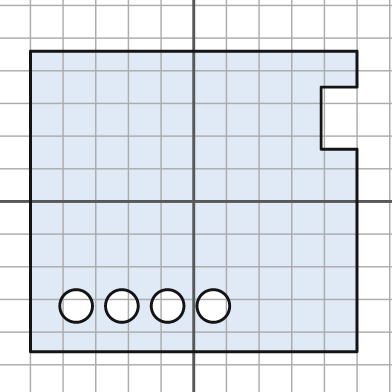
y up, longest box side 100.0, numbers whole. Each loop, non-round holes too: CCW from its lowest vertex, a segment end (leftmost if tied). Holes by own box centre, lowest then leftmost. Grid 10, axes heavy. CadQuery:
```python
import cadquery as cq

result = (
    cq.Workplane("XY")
    .moveTo(-50.0, -46.0)
    .lineTo(50.0, -46.0)
    .lineTo(50.0, 16.0)
    .lineTo(39.0, 16.0)
    .lineTo(39.0, 35.0)
    .lineTo(50.0, 35.0)
    .lineTo(50.0, 46.0)
    .lineTo(-50.0, 46.0)
    .close()
    .moveTo(-36.0, -32.0)
    .circle(5.0)
    .moveTo(-22.0, -32.0)
    .circle(5.0)
    .moveTo(-8.0, -32.0)
    .circle(5.0)
    .moveTo(6.0, -32.0)
    .circle(5.0)
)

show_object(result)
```